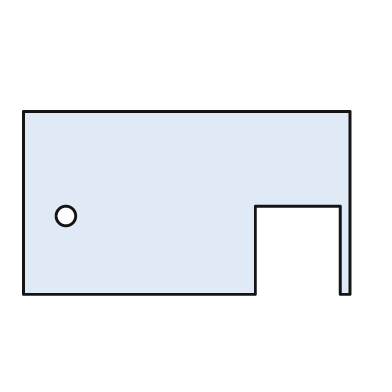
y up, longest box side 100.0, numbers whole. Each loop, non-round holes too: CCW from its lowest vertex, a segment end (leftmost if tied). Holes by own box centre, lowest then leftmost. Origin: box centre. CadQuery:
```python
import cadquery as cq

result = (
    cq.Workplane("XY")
    .moveTo(-50.0, -28.0)
    .lineTo(21.0, -28.0)
    .lineTo(21.0, -1.0)
    .lineTo(47.0, -1.0)
    .lineTo(47.0, -28.0)
    .lineTo(50.0, -28.0)
    .lineTo(50.0, 28.0)
    .lineTo(-50.0, 28.0)
    .close()
    .moveTo(-37.0, -4.0)
    .circle(3.0)
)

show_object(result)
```